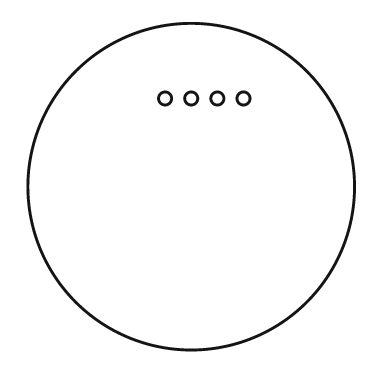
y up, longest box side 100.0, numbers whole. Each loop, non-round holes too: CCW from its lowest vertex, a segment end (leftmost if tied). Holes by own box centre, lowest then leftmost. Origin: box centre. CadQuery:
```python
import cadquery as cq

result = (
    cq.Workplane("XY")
    .moveTo(0.0, 0.0)
    .circle(50.0)
    .moveTo(-8.0, 27.0)
    .circle(2.0)
    .moveTo(0.0, 27.0)
    .circle(2.0)
    .moveTo(8.0, 27.0)
    .circle(2.0)
    .moveTo(16.0, 27.0)
    .circle(2.0)
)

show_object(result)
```